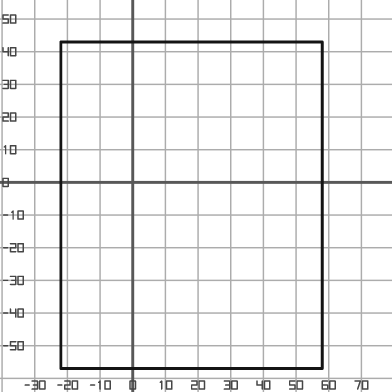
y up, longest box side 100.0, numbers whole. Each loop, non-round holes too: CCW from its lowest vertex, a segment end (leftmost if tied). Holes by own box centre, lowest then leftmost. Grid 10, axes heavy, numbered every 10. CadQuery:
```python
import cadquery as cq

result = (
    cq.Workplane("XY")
    .moveTo(-22.0, -57.0)
    .lineTo(58.0, -57.0)
    .lineTo(58.0, 43.0)
    .lineTo(-22.0, 43.0)
    .close()
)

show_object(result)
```